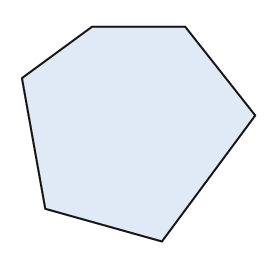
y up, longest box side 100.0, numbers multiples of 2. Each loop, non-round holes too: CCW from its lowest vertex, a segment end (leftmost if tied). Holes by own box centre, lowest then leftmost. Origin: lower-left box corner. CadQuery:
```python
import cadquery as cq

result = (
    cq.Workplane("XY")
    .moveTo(60.0, 0.0)
    .lineTo(100.0, 54.0)
    .lineTo(70.0, 92.0)
    .lineTo(30.0, 92.0)
    .lineTo(0.0, 70.0)
    .lineTo(10.0, 14.0)
    .close()
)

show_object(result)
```